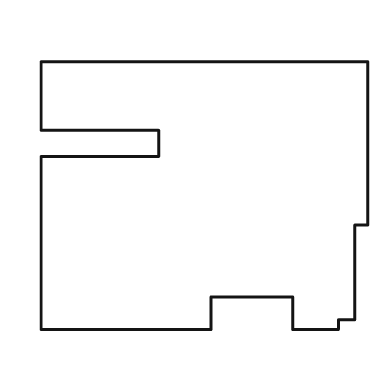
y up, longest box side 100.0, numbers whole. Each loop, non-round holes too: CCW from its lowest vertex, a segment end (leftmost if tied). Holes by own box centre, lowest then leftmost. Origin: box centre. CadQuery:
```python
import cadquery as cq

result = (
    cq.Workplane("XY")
    .moveTo(-50.0, -41.0)
    .lineTo(2.0, -41.0)
    .lineTo(2.0, -31.0)
    .lineTo(27.0, -31.0)
    .lineTo(27.0, -41.0)
    .lineTo(41.0, -41.0)
    .lineTo(41.0, -38.0)
    .lineTo(46.0, -38.0)
    .lineTo(46.0, -9.0)
    .lineTo(50.0, -9.0)
    .lineTo(50.0, 41.0)
    .lineTo(-50.0, 41.0)
    .lineTo(-50.0, 20.0)
    .lineTo(-14.0, 20.0)
    .lineTo(-14.0, 12.0)
    .lineTo(-50.0, 12.0)
    .close()
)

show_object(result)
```